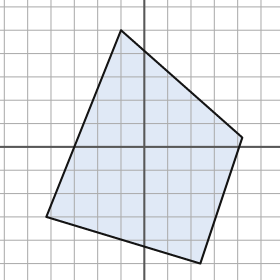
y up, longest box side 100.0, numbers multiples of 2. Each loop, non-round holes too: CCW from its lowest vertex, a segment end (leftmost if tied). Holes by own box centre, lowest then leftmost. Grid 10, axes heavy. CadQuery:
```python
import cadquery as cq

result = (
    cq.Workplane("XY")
    .moveTo(24.0, -50.0)
    .lineTo(42.0, 4.0)
    .lineTo(-10.0, 50.0)
    .lineTo(-42.0, -30.0)
    .close()
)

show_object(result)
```